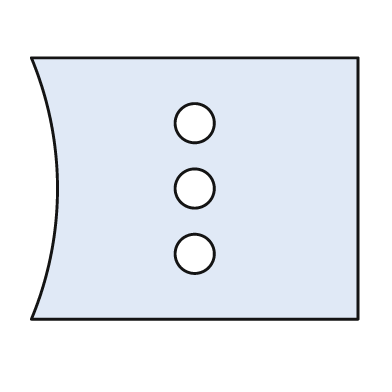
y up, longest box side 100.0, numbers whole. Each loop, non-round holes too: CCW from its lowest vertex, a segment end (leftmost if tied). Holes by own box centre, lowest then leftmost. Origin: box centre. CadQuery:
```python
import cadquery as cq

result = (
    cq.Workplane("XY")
    .moveTo(-50.0, -40.0)
    .lineTo(50.0, -40.0)
    .lineTo(50.0, 40.0)
    .lineTo(-50.0, 40.0)
    .threePointArc((-42.0, 0.0), (-50.0, -40.0))
    .close()
    .moveTo(0.0, -20.0)
    .circle(6.0)
    .moveTo(0.0, 0.0)
    .circle(6.0)
    .moveTo(0.0, 20.0)
    .circle(6.0)
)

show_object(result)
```